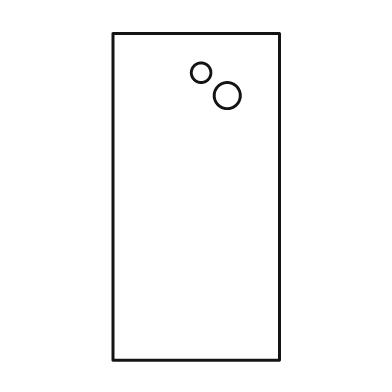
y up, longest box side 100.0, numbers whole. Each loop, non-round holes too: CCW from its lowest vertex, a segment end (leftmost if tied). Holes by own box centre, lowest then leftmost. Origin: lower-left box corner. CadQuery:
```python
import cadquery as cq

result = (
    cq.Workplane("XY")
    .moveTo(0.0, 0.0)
    .lineTo(51.0, 0.0)
    .lineTo(51.0, 100.0)
    .lineTo(0.0, 100.0)
    .close()
    .moveTo(35.0, 81.0)
    .circle(4.0)
    .moveTo(27.0, 88.0)
    .circle(3.0)
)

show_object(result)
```